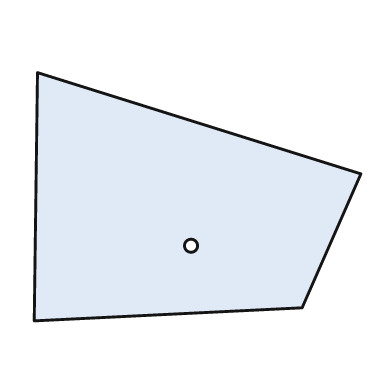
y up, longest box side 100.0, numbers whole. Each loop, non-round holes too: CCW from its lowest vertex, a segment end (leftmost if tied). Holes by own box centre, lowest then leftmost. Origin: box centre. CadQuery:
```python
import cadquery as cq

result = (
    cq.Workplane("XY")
    .moveTo(-50.0, -38.0)
    .lineTo(32.0, -34.0)
    .lineTo(50.0, 7.0)
    .lineTo(-49.0, 38.0)
    .close()
    .moveTo(-2.0, -15.0)
    .circle(2.0)
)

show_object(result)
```